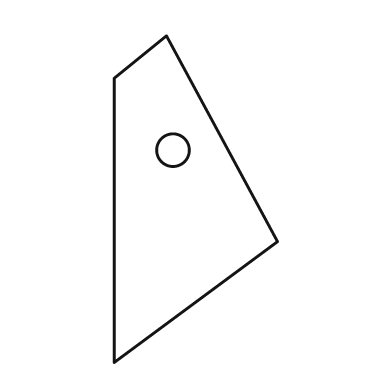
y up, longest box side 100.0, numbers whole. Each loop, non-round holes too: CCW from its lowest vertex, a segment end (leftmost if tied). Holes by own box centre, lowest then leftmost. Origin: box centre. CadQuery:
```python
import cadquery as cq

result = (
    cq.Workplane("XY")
    .moveTo(-25.0, -50.0)
    .lineTo(25.0, -13.0)
    .lineTo(-9.0, 50.0)
    .lineTo(-25.0, 37.0)
    .close()
    .moveTo(-7.0, 15.0)
    .circle(5.0)
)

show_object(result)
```